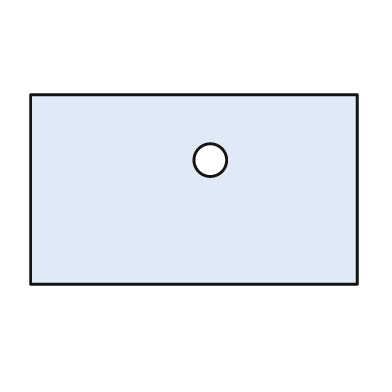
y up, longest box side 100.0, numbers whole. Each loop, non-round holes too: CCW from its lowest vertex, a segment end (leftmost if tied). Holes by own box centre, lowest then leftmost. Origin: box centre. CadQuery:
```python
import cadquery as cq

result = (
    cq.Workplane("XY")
    .moveTo(-50.0, -29.0)
    .lineTo(50.0, -29.0)
    .lineTo(50.0, 29.0)
    .lineTo(-50.0, 29.0)
    .close()
    .moveTo(5.0, 9.0)
    .circle(5.0)
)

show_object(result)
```